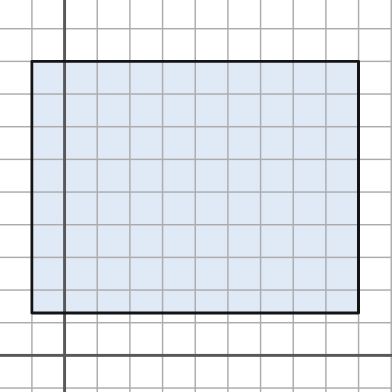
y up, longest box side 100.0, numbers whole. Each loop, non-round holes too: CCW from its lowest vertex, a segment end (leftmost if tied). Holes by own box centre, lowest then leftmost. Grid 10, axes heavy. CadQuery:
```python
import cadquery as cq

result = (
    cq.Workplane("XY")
    .moveTo(-10.0, 13.0)
    .lineTo(90.0, 13.0)
    .lineTo(90.0, 90.0)
    .lineTo(-10.0, 90.0)
    .close()
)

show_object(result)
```